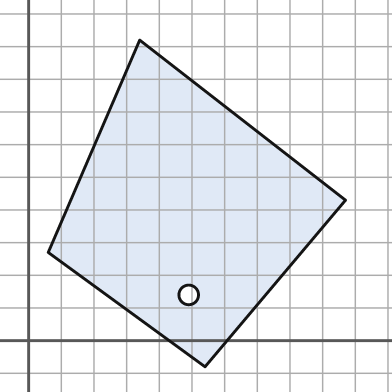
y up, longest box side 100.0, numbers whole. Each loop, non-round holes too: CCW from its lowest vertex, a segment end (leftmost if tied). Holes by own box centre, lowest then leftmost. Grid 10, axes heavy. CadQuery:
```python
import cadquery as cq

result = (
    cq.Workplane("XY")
    .moveTo(54.0, -8.0)
    .lineTo(97.0, 43.0)
    .lineTo(34.0, 92.0)
    .lineTo(6.0, 27.0)
    .close()
    .moveTo(49.0, 14.0)
    .circle(3.0)
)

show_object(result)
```